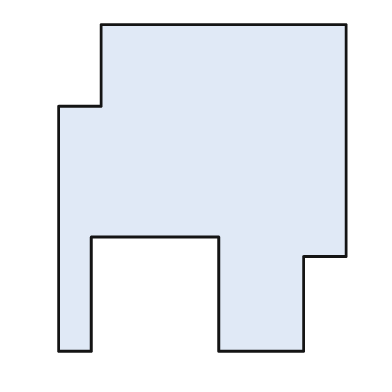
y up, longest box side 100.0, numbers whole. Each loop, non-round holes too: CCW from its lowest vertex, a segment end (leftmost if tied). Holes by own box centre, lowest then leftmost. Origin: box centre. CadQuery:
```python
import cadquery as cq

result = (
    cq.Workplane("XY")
    .moveTo(-44.0, -50.0)
    .lineTo(-34.0, -50.0)
    .lineTo(-34.0, -15.0)
    .lineTo(5.0, -15.0)
    .lineTo(5.0, -50.0)
    .lineTo(31.0, -50.0)
    .lineTo(31.0, -21.0)
    .lineTo(44.0, -21.0)
    .lineTo(44.0, 50.0)
    .lineTo(-31.0, 50.0)
    .lineTo(-31.0, 25.0)
    .lineTo(-44.0, 25.0)
    .close()
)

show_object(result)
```